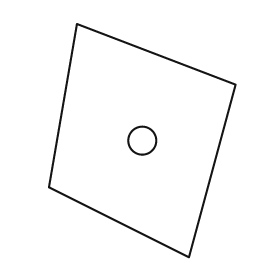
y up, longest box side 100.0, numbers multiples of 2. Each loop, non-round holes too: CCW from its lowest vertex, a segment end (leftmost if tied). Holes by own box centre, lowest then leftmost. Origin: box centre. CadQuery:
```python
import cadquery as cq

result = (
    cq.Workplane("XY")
    .moveTo(20.0, -50.0)
    .lineTo(40.0, 24.0)
    .lineTo(-28.0, 50.0)
    .lineTo(-40.0, -20.0)
    .close()
    .moveTo(0.0, 0.0)
    .circle(6.0)
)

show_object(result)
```